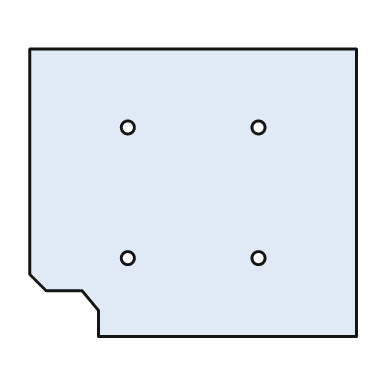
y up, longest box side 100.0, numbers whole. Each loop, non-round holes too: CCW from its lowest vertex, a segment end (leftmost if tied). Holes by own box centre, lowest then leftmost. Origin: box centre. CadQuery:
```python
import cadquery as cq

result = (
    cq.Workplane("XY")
    .moveTo(-29.0, -44.0)
    .lineTo(50.0, -44.0)
    .lineTo(50.0, 44.0)
    .lineTo(-50.0, 44.0)
    .lineTo(-50.0, -25.0)
    .lineTo(-45.0, -30.0)
    .lineTo(-34.0, -30.0)
    .lineTo(-29.0, -36.0)
    .close()
    .moveTo(-20.0, -20.0)
    .circle(2.0)
    .moveTo(20.0, -20.0)
    .circle(2.0)
    .moveTo(-20.0, 20.0)
    .circle(2.0)
    .moveTo(20.0, 20.0)
    .circle(2.0)
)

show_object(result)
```